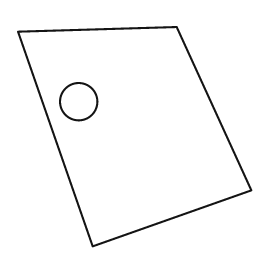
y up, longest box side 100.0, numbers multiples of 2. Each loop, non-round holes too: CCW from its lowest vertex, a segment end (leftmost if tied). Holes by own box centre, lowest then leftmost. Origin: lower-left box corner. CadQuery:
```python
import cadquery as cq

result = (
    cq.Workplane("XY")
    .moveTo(32.0, 0.0)
    .lineTo(100.0, 24.0)
    .lineTo(68.0, 94.0)
    .lineTo(0.0, 92.0)
    .close()
    .moveTo(26.0, 62.0)
    .circle(8.0)
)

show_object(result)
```